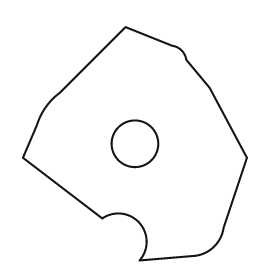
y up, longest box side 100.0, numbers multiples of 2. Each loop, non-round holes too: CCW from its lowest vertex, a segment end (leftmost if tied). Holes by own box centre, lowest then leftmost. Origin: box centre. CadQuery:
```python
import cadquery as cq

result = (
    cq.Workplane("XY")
    .moveTo(2.0, -50.0)
    .lineTo(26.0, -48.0)
    .threePointArc((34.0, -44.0), (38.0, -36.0))
    .lineTo(48.0, -6.0)
    .lineTo(32.0, 24.0)
    .lineTo(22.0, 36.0)
    .threePointArc((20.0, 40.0), (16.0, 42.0))
    .lineTo(-4.0, 50.0)
    .lineTo(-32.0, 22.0)
    .threePointArc((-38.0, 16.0), (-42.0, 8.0))
    .lineTo(-48.0, -6.0)
    .lineTo(-14.0, -32.0)
    .threePointArc((2.0, -34.0), (2.0, -50.0))
    .close()
    .moveTo(0.0, 0.0)
    .circle(10.0)
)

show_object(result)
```